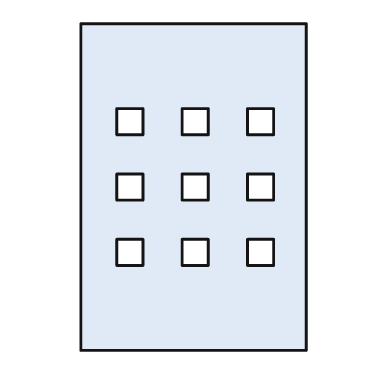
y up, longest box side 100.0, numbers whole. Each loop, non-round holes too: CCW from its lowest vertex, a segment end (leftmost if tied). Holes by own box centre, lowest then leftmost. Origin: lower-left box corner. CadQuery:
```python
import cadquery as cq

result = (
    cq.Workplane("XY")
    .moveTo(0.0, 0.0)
    .lineTo(69.0, 0.0)
    .lineTo(69.0, 100.0)
    .lineTo(0.0, 100.0)
    .close()
    .moveTo(11.0, 26.0)
    .lineTo(19.0, 26.0)
    .lineTo(19.0, 34.0)
    .lineTo(11.0, 34.0)
    .close()
    .moveTo(31.0, 26.0)
    .lineTo(39.0, 26.0)
    .lineTo(39.0, 34.0)
    .lineTo(31.0, 34.0)
    .close()
    .moveTo(51.0, 26.0)
    .lineTo(59.0, 26.0)
    .lineTo(59.0, 34.0)
    .lineTo(51.0, 34.0)
    .close()
    .moveTo(11.0, 46.0)
    .lineTo(19.0, 46.0)
    .lineTo(19.0, 54.0)
    .lineTo(11.0, 54.0)
    .close()
    .moveTo(31.0, 46.0)
    .lineTo(39.0, 46.0)
    .lineTo(39.0, 54.0)
    .lineTo(31.0, 54.0)
    .close()
    .moveTo(51.0, 46.0)
    .lineTo(59.0, 46.0)
    .lineTo(59.0, 54.0)
    .lineTo(51.0, 54.0)
    .close()
    .moveTo(11.0, 66.0)
    .lineTo(19.0, 66.0)
    .lineTo(19.0, 74.0)
    .lineTo(11.0, 74.0)
    .close()
    .moveTo(31.0, 66.0)
    .lineTo(39.0, 66.0)
    .lineTo(39.0, 74.0)
    .lineTo(31.0, 74.0)
    .close()
    .moveTo(51.0, 66.0)
    .lineTo(59.0, 66.0)
    .lineTo(59.0, 74.0)
    .lineTo(51.0, 74.0)
    .close()
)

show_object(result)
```